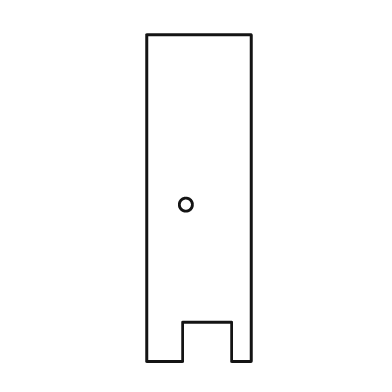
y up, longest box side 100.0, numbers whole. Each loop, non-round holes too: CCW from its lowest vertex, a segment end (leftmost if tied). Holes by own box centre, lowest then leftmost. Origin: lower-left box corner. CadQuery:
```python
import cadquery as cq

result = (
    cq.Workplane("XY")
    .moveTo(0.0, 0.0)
    .lineTo(11.0, 0.0)
    .lineTo(11.0, 12.0)
    .lineTo(26.0, 12.0)
    .lineTo(26.0, 0.0)
    .lineTo(32.0, 0.0)
    .lineTo(32.0, 100.0)
    .lineTo(0.0, 100.0)
    .close()
    .moveTo(12.0, 48.0)
    .circle(2.0)
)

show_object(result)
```